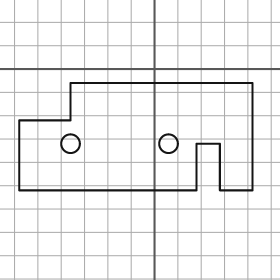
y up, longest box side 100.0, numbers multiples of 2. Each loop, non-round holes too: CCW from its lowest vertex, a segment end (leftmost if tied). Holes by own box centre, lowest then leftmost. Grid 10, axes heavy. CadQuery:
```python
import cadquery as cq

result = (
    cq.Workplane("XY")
    .moveTo(-58.0, -52.0)
    .lineTo(18.0, -52.0)
    .lineTo(18.0, -32.0)
    .lineTo(28.0, -32.0)
    .lineTo(28.0, -52.0)
    .lineTo(42.0, -52.0)
    .lineTo(42.0, -6.0)
    .lineTo(-36.0, -6.0)
    .lineTo(-36.0, -22.0)
    .lineTo(-58.0, -22.0)
    .close()
    .moveTo(-36.0, -32.0)
    .circle(4.0)
    .moveTo(6.0, -32.0)
    .circle(4.0)
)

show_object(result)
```